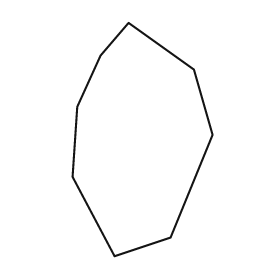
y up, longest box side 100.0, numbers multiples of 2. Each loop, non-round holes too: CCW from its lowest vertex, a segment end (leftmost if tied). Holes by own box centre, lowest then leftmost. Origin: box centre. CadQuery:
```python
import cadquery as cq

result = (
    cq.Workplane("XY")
    .moveTo(-12.0, -50.0)
    .lineTo(12.0, -42.0)
    .lineTo(30.0, 2.0)
    .lineTo(22.0, 30.0)
    .lineTo(-6.0, 50.0)
    .lineTo(-18.0, 36.0)
    .lineTo(-28.0, 14.0)
    .lineTo(-30.0, -16.0)
    .close()
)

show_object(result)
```